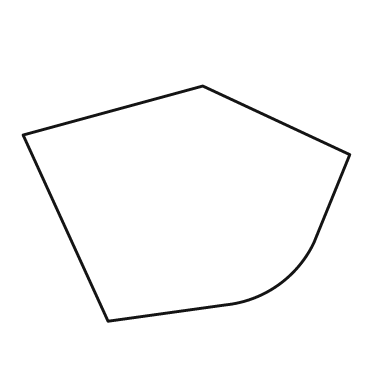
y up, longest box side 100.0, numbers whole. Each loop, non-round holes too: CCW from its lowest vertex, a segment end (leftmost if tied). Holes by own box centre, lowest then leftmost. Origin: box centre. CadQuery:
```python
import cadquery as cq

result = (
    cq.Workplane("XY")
    .moveTo(-24.0, -36.0)
    .lineTo(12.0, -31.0)
    .threePointArc((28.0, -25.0), (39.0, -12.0))
    .lineTo(50.0, 15.0)
    .lineTo(5.0, 36.0)
    .lineTo(-50.0, 21.0)
    .close()
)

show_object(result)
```